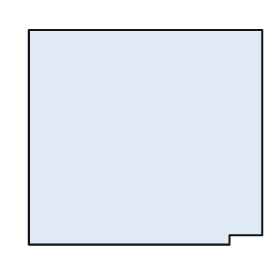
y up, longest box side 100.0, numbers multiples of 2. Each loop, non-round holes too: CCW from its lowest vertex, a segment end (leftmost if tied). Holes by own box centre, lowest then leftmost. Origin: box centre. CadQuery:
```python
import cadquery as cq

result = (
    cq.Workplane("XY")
    .moveTo(-50.0, -46.0)
    .lineTo(36.0, -46.0)
    .lineTo(36.0, -42.0)
    .lineTo(50.0, -42.0)
    .lineTo(50.0, 46.0)
    .lineTo(-50.0, 46.0)
    .close()
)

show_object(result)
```